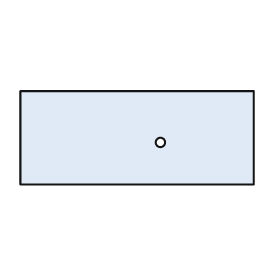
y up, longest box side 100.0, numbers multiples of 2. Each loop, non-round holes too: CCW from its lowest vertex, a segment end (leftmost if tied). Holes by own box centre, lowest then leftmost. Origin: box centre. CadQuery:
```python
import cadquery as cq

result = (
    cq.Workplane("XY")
    .moveTo(-50.0, -20.0)
    .lineTo(50.0, -20.0)
    .lineTo(50.0, 20.0)
    .lineTo(-50.0, 20.0)
    .close()
    .moveTo(10.0, -2.0)
    .circle(2.0)
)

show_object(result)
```